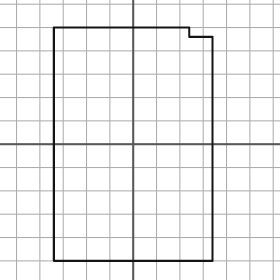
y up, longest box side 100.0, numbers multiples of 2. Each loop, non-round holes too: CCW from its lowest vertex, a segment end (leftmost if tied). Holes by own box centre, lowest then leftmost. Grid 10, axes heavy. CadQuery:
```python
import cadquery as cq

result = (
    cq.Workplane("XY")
    .moveTo(-34.0, -50.0)
    .lineTo(34.0, -50.0)
    .lineTo(34.0, 46.0)
    .lineTo(24.0, 46.0)
    .lineTo(24.0, 50.0)
    .lineTo(-34.0, 50.0)
    .close()
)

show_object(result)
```